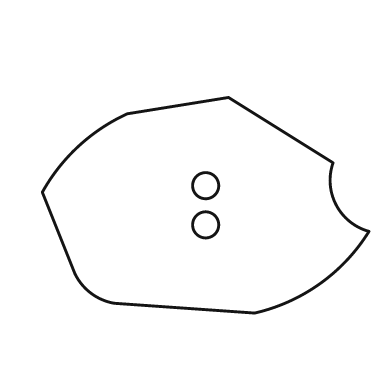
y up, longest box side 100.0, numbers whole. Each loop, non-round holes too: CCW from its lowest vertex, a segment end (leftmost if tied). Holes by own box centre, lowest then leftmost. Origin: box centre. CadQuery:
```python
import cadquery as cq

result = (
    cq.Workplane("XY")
    .moveTo(15.0, -33.0)
    .threePointArc((35.0, -24.0), (50.0, -8.0))
    .threePointArc((40.0, 0.0), (39.0, 13.0))
    .lineTo(7.0, 33.0)
    .lineTo(-24.0, 28.0)
    .threePointArc((-39.0, 18.0), (-50.0, 4.0))
    .lineTo(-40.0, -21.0)
    .threePointArc((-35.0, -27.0), (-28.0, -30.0))
    .close()
    .moveTo(0.0, -6.0)
    .circle(4.0)
    .moveTo(0.0, 6.0)
    .circle(4.0)
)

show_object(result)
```